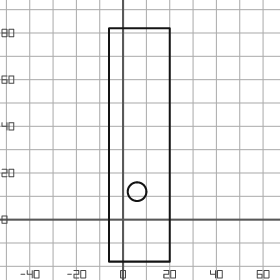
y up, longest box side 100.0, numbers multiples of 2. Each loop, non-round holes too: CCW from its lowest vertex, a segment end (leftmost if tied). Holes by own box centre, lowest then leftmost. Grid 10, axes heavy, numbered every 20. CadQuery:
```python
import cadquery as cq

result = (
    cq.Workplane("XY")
    .moveTo(-6.0, -18.0)
    .lineTo(20.0, -18.0)
    .lineTo(20.0, 82.0)
    .lineTo(-6.0, 82.0)
    .close()
    .moveTo(6.0, 12.0)
    .circle(4.0)
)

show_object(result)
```